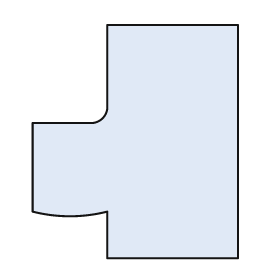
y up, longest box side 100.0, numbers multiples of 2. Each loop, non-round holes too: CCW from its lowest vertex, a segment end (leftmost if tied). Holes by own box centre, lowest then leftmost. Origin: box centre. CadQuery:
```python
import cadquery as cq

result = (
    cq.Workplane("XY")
    .moveTo(-12.0, -50.0)
    .lineTo(44.0, -50.0)
    .lineTo(44.0, 50.0)
    .lineTo(-12.0, 50.0)
    .lineTo(-12.0, 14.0)
    .threePointArc((-14.0, 10.0), (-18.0, 8.0))
    .lineTo(-44.0, 8.0)
    .lineTo(-44.0, -30.0)
    .threePointArc((-28.0, -32.0), (-12.0, -30.0))
    .close()
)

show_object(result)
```